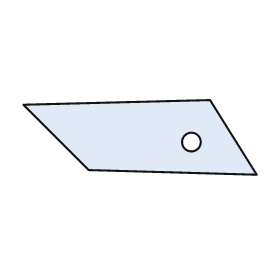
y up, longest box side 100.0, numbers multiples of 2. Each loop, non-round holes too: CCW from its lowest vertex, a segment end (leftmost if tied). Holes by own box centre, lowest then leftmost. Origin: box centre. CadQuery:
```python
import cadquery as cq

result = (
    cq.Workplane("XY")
    .moveTo(50.0, -16.0)
    .lineTo(30.0, 16.0)
    .lineTo(-50.0, 14.0)
    .lineTo(-22.0, -14.0)
    .close()
    .moveTo(22.0, -2.0)
    .circle(4.0)
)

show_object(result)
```